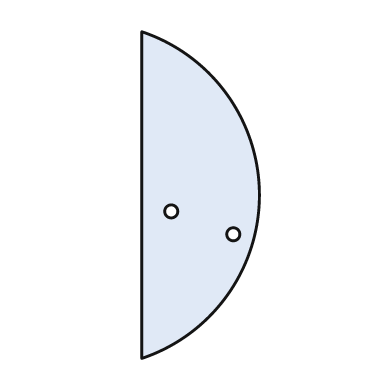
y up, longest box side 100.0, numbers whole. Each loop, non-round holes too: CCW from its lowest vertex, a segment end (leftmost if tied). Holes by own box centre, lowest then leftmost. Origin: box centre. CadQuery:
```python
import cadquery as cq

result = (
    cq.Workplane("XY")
    .moveTo(-18.0, -50.0)
    .threePointArc((18.0, 0.0), (-18.0, 50.0))
    .close()
    .moveTo(10.0, -12.0)
    .circle(2.0)
    .moveTo(-9.0, -5.0)
    .circle(2.0)
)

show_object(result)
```